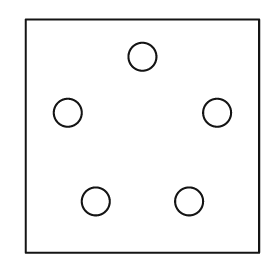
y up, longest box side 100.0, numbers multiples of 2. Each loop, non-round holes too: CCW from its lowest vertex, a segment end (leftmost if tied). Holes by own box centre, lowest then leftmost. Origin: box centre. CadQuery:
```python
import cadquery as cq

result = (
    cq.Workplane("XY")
    .moveTo(-50.0, -50.0)
    .lineTo(50.0, -50.0)
    .lineTo(50.0, 50.0)
    .lineTo(-50.0, 50.0)
    .close()
    .moveTo(-20.0, -28.0)
    .circle(6.0)
    .moveTo(20.0, -28.0)
    .circle(6.0)
    .moveTo(-32.0, 10.0)
    .circle(6.0)
    .moveTo(32.0, 10.0)
    .circle(6.0)
    .moveTo(0.0, 34.0)
    .circle(6.0)
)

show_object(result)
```